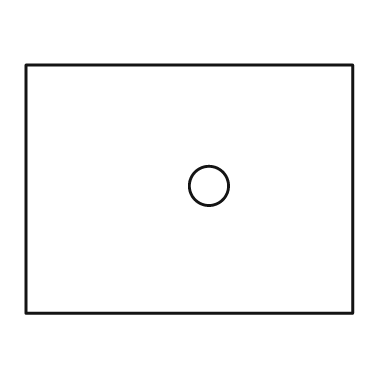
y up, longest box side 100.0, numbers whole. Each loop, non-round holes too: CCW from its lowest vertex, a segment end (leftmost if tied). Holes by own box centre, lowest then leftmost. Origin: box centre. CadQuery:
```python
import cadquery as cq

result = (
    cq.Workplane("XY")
    .moveTo(-50.0, -38.0)
    .lineTo(50.0, -38.0)
    .lineTo(50.0, 38.0)
    .lineTo(-50.0, 38.0)
    .close()
    .moveTo(6.0, 1.0)
    .circle(6.0)
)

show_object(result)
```